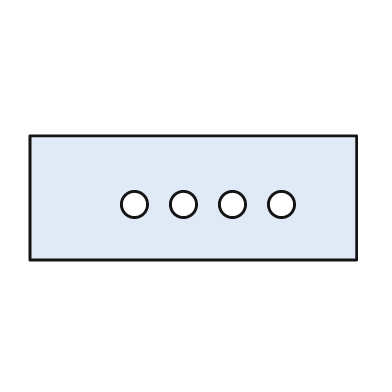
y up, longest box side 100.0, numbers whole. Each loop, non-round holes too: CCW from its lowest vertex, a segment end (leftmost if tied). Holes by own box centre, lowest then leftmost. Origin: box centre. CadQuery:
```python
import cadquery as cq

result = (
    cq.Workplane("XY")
    .moveTo(-50.0, -19.0)
    .lineTo(50.0, -19.0)
    .lineTo(50.0, 19.0)
    .lineTo(-50.0, 19.0)
    .close()
    .moveTo(-18.0, -2.0)
    .circle(4.0)
    .moveTo(-3.0, -2.0)
    .circle(4.0)
    .moveTo(12.0, -2.0)
    .circle(4.0)
    .moveTo(27.0, -2.0)
    .circle(4.0)
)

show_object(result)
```